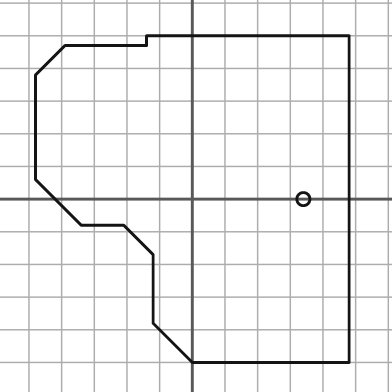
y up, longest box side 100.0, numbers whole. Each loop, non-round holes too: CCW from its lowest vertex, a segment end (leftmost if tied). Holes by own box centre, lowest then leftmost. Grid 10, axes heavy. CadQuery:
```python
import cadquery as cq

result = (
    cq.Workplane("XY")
    .moveTo(0.0, -50.0)
    .lineTo(48.0, -50.0)
    .lineTo(48.0, 50.0)
    .lineTo(-14.0, 50.0)
    .lineTo(-14.0, 47.0)
    .lineTo(-39.0, 47.0)
    .lineTo(-48.0, 38.0)
    .lineTo(-48.0, 6.0)
    .lineTo(-34.0, -8.0)
    .lineTo(-21.0, -8.0)
    .lineTo(-12.0, -17.0)
    .lineTo(-12.0, -38.0)
    .close()
    .moveTo(34.0, 0.0)
    .circle(2.0)
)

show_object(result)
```